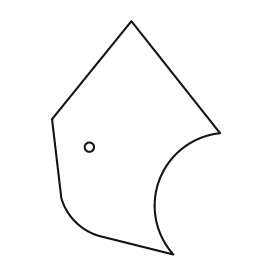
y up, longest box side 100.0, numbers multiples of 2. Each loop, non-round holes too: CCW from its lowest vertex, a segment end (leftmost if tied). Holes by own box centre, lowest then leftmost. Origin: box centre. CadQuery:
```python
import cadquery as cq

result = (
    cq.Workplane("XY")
    .moveTo(16.0, -50.0)
    .threePointArc((10.0, -18.0), (36.0, 2.0))
    .lineTo(-2.0, 50.0)
    .lineTo(-36.0, 8.0)
    .lineTo(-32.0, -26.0)
    .threePointArc((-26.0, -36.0), (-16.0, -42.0))
    .close()
    .moveTo(-20.0, -4.0)
    .circle(2.0)
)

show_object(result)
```